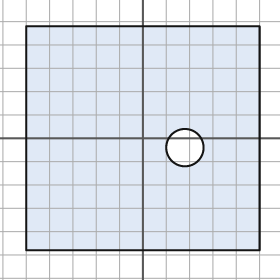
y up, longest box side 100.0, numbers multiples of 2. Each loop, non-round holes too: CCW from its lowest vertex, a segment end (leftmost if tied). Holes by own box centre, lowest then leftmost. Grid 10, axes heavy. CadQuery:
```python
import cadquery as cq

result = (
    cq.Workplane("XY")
    .moveTo(-50.0, -48.0)
    .lineTo(50.0, -48.0)
    .lineTo(50.0, 48.0)
    .lineTo(-50.0, 48.0)
    .close()
    .moveTo(18.0, -4.0)
    .circle(8.0)
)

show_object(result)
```